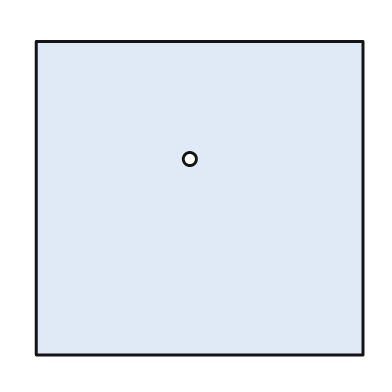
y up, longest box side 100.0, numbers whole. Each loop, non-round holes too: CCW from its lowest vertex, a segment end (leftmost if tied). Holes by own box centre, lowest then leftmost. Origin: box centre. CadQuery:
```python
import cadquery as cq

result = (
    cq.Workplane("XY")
    .moveTo(-50.0, -48.0)
    .lineTo(50.0, -48.0)
    .lineTo(50.0, 48.0)
    .lineTo(-50.0, 48.0)
    .close()
    .moveTo(-3.0, 12.0)
    .circle(2.0)
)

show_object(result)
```